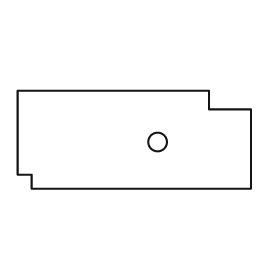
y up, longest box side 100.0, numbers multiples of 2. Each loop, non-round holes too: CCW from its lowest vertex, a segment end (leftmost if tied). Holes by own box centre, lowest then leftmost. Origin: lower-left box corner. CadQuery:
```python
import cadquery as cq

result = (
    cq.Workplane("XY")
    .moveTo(6.0, 0.0)
    .lineTo(100.0, 0.0)
    .lineTo(100.0, 34.0)
    .lineTo(82.0, 34.0)
    .lineTo(82.0, 42.0)
    .lineTo(0.0, 42.0)
    .lineTo(0.0, 6.0)
    .lineTo(6.0, 6.0)
    .close()
    .moveTo(60.0, 20.0)
    .circle(4.0)
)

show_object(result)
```